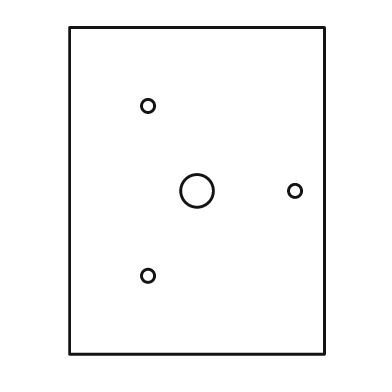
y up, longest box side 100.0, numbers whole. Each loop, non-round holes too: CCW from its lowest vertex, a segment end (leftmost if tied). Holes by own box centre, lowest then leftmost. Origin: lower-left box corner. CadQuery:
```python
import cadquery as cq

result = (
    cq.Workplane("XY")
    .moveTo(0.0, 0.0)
    .lineTo(78.0, 0.0)
    .lineTo(78.0, 100.0)
    .lineTo(0.0, 100.0)
    .close()
    .moveTo(24.0, 24.0)
    .circle(2.0)
    .moveTo(39.0, 50.0)
    .circle(5.0)
    .moveTo(69.0, 50.0)
    .circle(2.0)
    .moveTo(24.0, 76.0)
    .circle(2.0)
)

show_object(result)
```